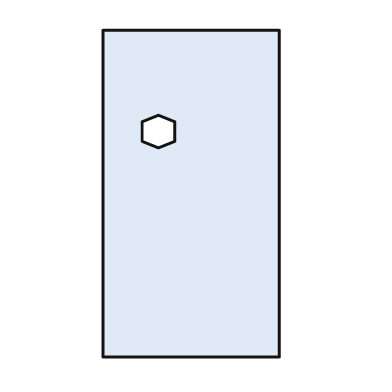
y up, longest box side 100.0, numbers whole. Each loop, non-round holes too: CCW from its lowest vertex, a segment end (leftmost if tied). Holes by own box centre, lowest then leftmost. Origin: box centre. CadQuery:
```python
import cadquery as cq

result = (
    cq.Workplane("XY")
    .moveTo(-27.0, -50.0)
    .lineTo(27.0, -50.0)
    .lineTo(27.0, 50.0)
    .lineTo(-27.0, 50.0)
    .close()
    .moveTo(-10.0, 14.0)
    .lineTo(-5.0, 16.0)
    .lineTo(-5.0, 22.0)
    .lineTo(-10.0, 24.0)
    .lineTo(-15.0, 22.0)
    .lineTo(-15.0, 16.0)
    .close()
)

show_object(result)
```